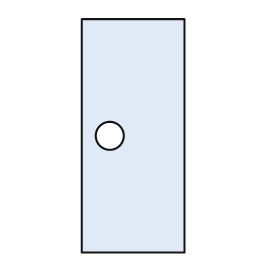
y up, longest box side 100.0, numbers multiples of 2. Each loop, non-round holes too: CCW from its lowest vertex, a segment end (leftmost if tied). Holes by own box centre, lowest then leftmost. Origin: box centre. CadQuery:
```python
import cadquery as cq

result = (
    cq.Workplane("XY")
    .moveTo(-22.0, -50.0)
    .lineTo(22.0, -50.0)
    .lineTo(22.0, 50.0)
    .lineTo(-22.0, 50.0)
    .close()
    .moveTo(-10.0, 0.0)
    .circle(6.0)
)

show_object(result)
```